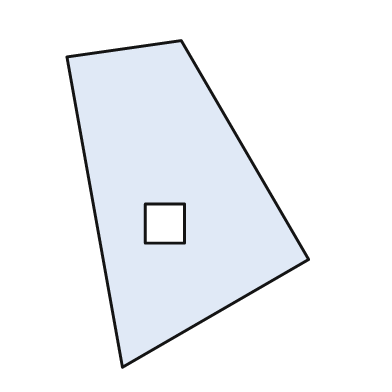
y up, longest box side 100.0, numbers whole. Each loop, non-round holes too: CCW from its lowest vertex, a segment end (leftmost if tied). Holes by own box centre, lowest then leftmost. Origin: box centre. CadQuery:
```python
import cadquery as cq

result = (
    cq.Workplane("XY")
    .moveTo(-20.0, -50.0)
    .lineTo(37.0, -17.0)
    .lineTo(-2.0, 50.0)
    .lineTo(-37.0, 45.0)
    .close()
    .moveTo(-13.0, -12.0)
    .lineTo(-1.0, -12.0)
    .lineTo(-1.0, 0.0)
    .lineTo(-13.0, 0.0)
    .close()
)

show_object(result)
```